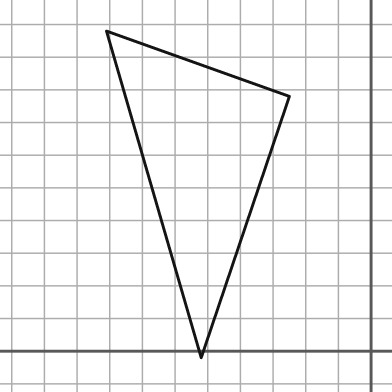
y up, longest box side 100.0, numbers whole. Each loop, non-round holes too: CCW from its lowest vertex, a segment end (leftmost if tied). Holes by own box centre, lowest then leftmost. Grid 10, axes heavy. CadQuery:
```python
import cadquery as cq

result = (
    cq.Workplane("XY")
    .moveTo(-52.0, -2.0)
    .lineTo(-25.0, 78.0)
    .lineTo(-81.0, 98.0)
    .close()
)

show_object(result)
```